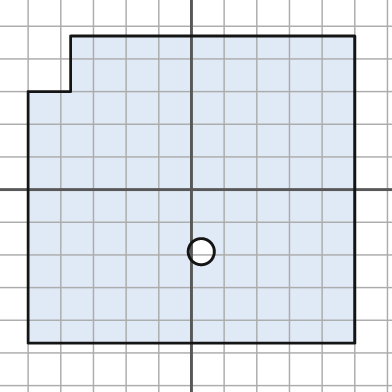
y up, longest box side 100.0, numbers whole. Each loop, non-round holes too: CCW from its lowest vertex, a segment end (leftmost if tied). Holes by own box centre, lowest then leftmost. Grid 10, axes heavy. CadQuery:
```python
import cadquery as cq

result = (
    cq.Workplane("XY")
    .moveTo(-50.0, -47.0)
    .lineTo(50.0, -47.0)
    .lineTo(50.0, 47.0)
    .lineTo(-37.0, 47.0)
    .lineTo(-37.0, 30.0)
    .lineTo(-50.0, 30.0)
    .close()
    .moveTo(3.0, -19.0)
    .circle(4.0)
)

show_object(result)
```